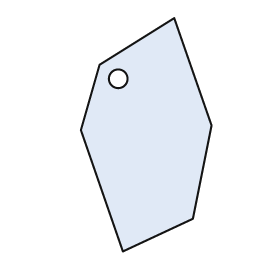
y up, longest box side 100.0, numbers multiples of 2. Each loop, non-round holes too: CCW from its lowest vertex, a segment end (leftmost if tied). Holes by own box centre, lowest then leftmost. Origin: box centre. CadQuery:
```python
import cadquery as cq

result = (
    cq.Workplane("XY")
    .moveTo(-10.0, -50.0)
    .lineTo(20.0, -36.0)
    .lineTo(28.0, 4.0)
    .lineTo(12.0, 50.0)
    .lineTo(-20.0, 30.0)
    .lineTo(-28.0, 2.0)
    .close()
    .moveTo(-12.0, 24.0)
    .circle(4.0)
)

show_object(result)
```